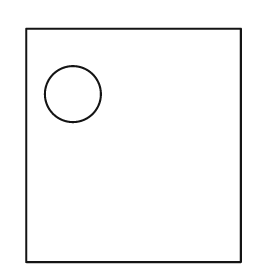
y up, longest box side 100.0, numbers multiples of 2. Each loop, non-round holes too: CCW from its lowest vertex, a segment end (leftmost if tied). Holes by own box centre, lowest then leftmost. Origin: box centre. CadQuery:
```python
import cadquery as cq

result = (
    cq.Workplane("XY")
    .moveTo(-46.0, -50.0)
    .lineTo(46.0, -50.0)
    .lineTo(46.0, 50.0)
    .lineTo(-46.0, 50.0)
    .close()
    .moveTo(-26.0, 22.0)
    .circle(12.0)
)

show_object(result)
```